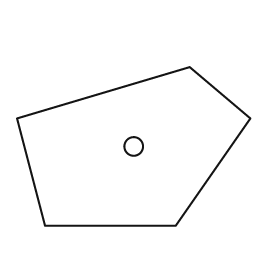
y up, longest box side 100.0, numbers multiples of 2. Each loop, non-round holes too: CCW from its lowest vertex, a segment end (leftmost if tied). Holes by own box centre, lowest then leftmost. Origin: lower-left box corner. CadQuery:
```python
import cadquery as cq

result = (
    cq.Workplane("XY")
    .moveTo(12.0, 0.0)
    .lineTo(68.0, 0.0)
    .lineTo(100.0, 46.0)
    .lineTo(74.0, 68.0)
    .lineTo(0.0, 46.0)
    .close()
    .moveTo(50.0, 34.0)
    .circle(4.0)
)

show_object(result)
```